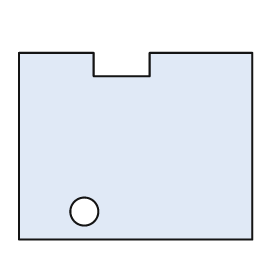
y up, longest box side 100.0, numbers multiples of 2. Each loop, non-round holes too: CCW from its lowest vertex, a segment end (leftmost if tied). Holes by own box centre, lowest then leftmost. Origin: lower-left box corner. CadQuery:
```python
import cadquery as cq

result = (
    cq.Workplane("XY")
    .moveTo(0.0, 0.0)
    .lineTo(100.0, 0.0)
    .lineTo(100.0, 80.0)
    .lineTo(56.0, 80.0)
    .lineTo(56.0, 70.0)
    .lineTo(32.0, 70.0)
    .lineTo(32.0, 80.0)
    .lineTo(0.0, 80.0)
    .close()
    .moveTo(28.0, 12.0)
    .circle(6.0)
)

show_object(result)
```